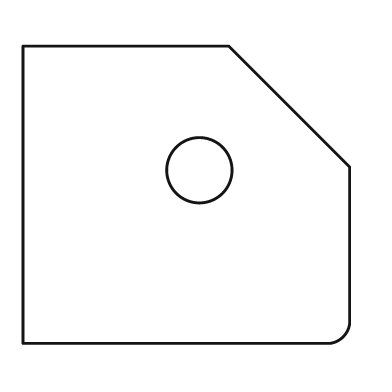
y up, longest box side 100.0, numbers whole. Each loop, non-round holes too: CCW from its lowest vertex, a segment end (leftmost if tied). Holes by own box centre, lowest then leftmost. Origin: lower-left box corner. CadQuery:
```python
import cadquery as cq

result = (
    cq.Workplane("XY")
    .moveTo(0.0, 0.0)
    .lineTo(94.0, 0.0)
    .threePointArc((98.0, 2.0), (100.0, 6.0))
    .lineTo(100.0, 54.0)
    .lineTo(63.0, 91.0)
    .lineTo(0.0, 91.0)
    .close()
    .moveTo(54.0, 53.0)
    .circle(10.0)
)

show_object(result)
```